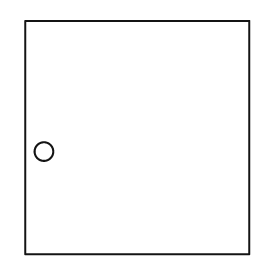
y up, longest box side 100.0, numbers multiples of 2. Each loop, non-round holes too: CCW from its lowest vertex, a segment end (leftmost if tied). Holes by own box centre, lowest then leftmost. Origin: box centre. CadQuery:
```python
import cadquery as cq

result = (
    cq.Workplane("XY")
    .moveTo(-48.0, -50.0)
    .lineTo(48.0, -50.0)
    .lineTo(48.0, 50.0)
    .lineTo(-48.0, 50.0)
    .close()
    .moveTo(-40.0, -6.0)
    .circle(4.0)
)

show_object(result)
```